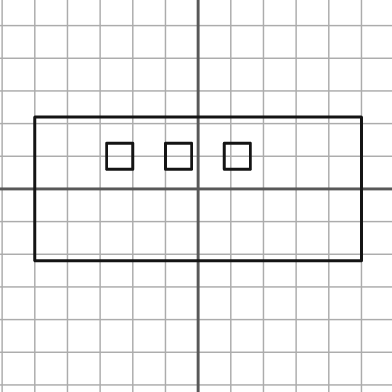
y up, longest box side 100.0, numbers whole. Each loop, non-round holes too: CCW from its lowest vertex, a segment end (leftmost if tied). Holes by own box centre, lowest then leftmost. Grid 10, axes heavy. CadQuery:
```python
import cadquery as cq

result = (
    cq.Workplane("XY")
    .moveTo(-50.0, -22.0)
    .lineTo(50.0, -22.0)
    .lineTo(50.0, 22.0)
    .lineTo(-50.0, 22.0)
    .close()
    .moveTo(-28.0, 6.0)
    .lineTo(-20.0, 6.0)
    .lineTo(-20.0, 14.0)
    .lineTo(-28.0, 14.0)
    .close()
    .moveTo(-10.0, 6.0)
    .lineTo(-2.0, 6.0)
    .lineTo(-2.0, 14.0)
    .lineTo(-10.0, 14.0)
    .close()
    .moveTo(8.0, 6.0)
    .lineTo(16.0, 6.0)
    .lineTo(16.0, 14.0)
    .lineTo(8.0, 14.0)
    .close()
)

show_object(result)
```